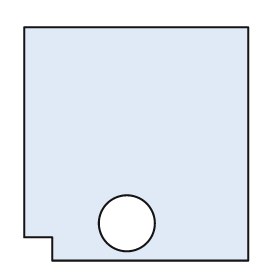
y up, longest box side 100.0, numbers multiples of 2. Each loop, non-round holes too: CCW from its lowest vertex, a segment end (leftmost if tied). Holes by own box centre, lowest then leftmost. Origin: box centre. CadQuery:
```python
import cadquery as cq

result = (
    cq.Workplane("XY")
    .moveTo(-36.0, -50.0)
    .lineTo(48.0, -50.0)
    .lineTo(48.0, 50.0)
    .lineTo(-48.0, 50.0)
    .lineTo(-48.0, -40.0)
    .lineTo(-36.0, -40.0)
    .close()
    .moveTo(-4.0, -34.0)
    .circle(12.0)
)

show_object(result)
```